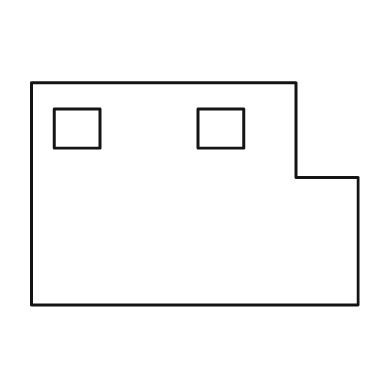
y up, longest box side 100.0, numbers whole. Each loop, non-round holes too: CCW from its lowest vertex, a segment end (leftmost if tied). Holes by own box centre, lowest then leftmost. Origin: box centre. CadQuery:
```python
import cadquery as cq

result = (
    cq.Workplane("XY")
    .moveTo(-50.0, -34.0)
    .lineTo(50.0, -34.0)
    .lineTo(50.0, 5.0)
    .lineTo(31.0, 5.0)
    .lineTo(31.0, 34.0)
    .lineTo(-50.0, 34.0)
    .close()
    .moveTo(-43.0, 14.0)
    .lineTo(-29.0, 14.0)
    .lineTo(-29.0, 26.0)
    .lineTo(-43.0, 26.0)
    .close()
    .moveTo(1.0, 14.0)
    .lineTo(15.0, 14.0)
    .lineTo(15.0, 26.0)
    .lineTo(1.0, 26.0)
    .close()
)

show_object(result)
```